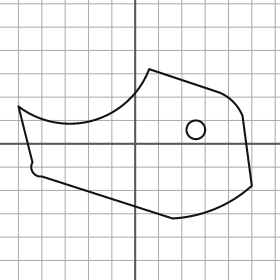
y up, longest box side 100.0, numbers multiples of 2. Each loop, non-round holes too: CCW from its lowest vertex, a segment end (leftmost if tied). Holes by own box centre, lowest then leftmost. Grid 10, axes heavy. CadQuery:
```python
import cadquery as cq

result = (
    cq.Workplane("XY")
    .moveTo(16.0, -32.0)
    .threePointArc((34.0, -28.0), (50.0, -18.0))
    .lineTo(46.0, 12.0)
    .threePointArc((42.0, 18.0), (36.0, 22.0))
    .lineTo(6.0, 32.0)
    .threePointArc((-18.0, 10.0), (-50.0, 16.0))
    .lineTo(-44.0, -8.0)
    .threePointArc((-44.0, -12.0), (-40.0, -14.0))
    .close()
    .moveTo(26.0, 6.0)
    .circle(4.0)
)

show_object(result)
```